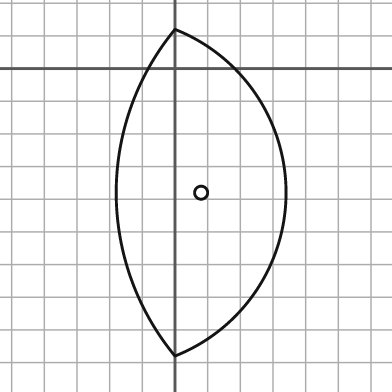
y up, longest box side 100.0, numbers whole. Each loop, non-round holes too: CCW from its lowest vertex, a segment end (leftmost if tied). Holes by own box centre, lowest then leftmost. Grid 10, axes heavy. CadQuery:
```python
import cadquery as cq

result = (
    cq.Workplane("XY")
    .moveTo(0.0, -88.0)
    .threePointArc((34.0, -38.0), (0.0, 12.0))
    .threePointArc((-18.0, -38.0), (0.0, -88.0))
    .close()
    .moveTo(8.0, -38.0)
    .circle(2.0)
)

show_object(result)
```